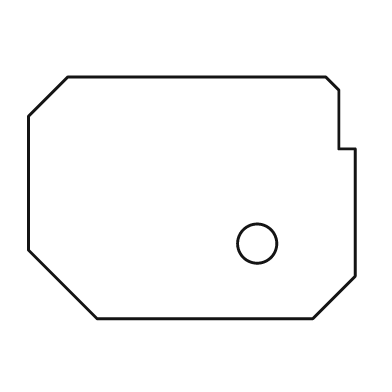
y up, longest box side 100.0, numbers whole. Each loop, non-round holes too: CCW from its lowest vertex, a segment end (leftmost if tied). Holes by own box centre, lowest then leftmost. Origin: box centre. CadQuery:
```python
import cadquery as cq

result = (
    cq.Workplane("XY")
    .moveTo(-29.0, -37.0)
    .lineTo(37.0, -37.0)
    .lineTo(50.0, -24.0)
    .lineTo(50.0, 15.0)
    .lineTo(45.0, 15.0)
    .lineTo(45.0, 33.0)
    .lineTo(41.0, 37.0)
    .lineTo(-38.0, 37.0)
    .lineTo(-50.0, 25.0)
    .lineTo(-50.0, -16.0)
    .close()
    .moveTo(20.0, -14.0)
    .circle(6.0)
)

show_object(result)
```